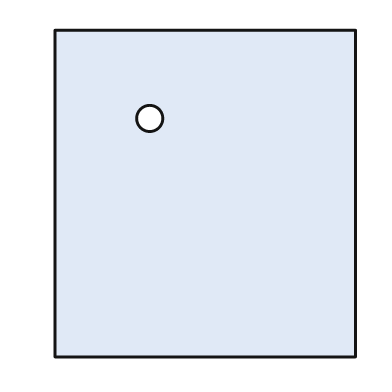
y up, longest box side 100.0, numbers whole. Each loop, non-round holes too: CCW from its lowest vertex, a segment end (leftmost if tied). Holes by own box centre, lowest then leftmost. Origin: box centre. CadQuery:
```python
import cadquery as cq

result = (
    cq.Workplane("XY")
    .moveTo(-46.0, -50.0)
    .lineTo(46.0, -50.0)
    .lineTo(46.0, 50.0)
    .lineTo(-46.0, 50.0)
    .close()
    .moveTo(-17.0, 23.0)
    .circle(4.0)
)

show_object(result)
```